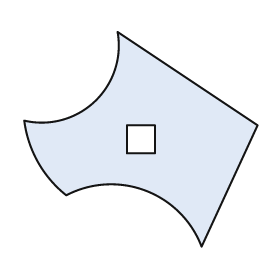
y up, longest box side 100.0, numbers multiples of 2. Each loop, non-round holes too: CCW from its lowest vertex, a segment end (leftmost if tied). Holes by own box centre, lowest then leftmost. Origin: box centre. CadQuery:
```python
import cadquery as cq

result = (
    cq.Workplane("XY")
    .moveTo(26.0, -46.0)
    .lineTo(50.0, 6.0)
    .lineTo(-10.0, 46.0)
    .threePointArc((-20.0, 16.0), (-50.0, 8.0))
    .threePointArc((-44.0, -10.0), (-32.0, -24.0))
    .threePointArc((2.0, -22.0), (26.0, -46.0))
    .close()
    .moveTo(-6.0, -6.0)
    .lineTo(6.0, -6.0)
    .lineTo(6.0, 6.0)
    .lineTo(-6.0, 6.0)
    .close()
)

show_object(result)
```